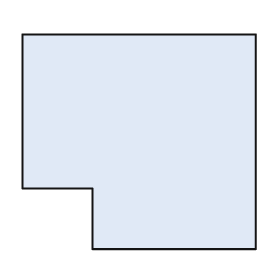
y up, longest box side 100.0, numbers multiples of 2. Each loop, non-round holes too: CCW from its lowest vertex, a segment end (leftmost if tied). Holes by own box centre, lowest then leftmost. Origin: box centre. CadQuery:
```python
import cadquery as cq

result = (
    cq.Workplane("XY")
    .moveTo(-20.0, -46.0)
    .lineTo(50.0, -46.0)
    .lineTo(50.0, 46.0)
    .lineTo(-50.0, 46.0)
    .lineTo(-50.0, -20.0)
    .lineTo(-20.0, -20.0)
    .close()
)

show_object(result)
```